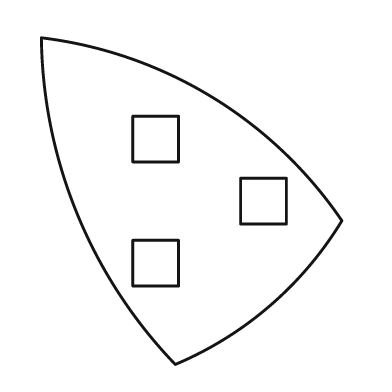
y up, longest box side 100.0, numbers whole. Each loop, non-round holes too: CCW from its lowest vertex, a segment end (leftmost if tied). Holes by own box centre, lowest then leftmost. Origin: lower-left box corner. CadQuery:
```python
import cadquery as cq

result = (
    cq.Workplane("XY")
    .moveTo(41.0, 0.0)
    .threePointArc((70.0, 18.0), (92.0, 44.0))
    .threePointArc((52.0, 82.0), (0.0, 100.0))
    .threePointArc((11.0, 46.0), (41.0, 0.0))
    .close()
    .moveTo(28.0, 24.0)
    .lineTo(42.0, 24.0)
    .lineTo(42.0, 38.0)
    .lineTo(28.0, 38.0)
    .close()
    .moveTo(61.0, 43.0)
    .lineTo(75.0, 43.0)
    .lineTo(75.0, 57.0)
    .lineTo(61.0, 57.0)
    .close()
    .moveTo(28.0, 62.0)
    .lineTo(42.0, 62.0)
    .lineTo(42.0, 76.0)
    .lineTo(28.0, 76.0)
    .close()
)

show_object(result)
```